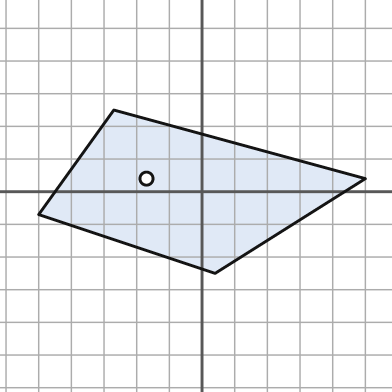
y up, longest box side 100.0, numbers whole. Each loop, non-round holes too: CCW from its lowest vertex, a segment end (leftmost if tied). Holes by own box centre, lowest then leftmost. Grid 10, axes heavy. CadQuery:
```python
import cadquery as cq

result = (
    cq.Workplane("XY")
    .moveTo(4.0, -25.0)
    .lineTo(50.0, 4.0)
    .lineTo(-27.0, 25.0)
    .lineTo(-50.0, -7.0)
    .close()
    .moveTo(-17.0, 4.0)
    .circle(2.0)
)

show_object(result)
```